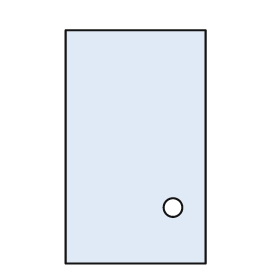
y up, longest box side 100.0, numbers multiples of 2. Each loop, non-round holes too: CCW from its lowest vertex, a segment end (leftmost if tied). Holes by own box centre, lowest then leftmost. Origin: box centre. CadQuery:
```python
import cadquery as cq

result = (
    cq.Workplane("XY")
    .moveTo(-30.0, -50.0)
    .lineTo(30.0, -50.0)
    .lineTo(30.0, 50.0)
    .lineTo(-30.0, 50.0)
    .close()
    .moveTo(16.0, -26.0)
    .circle(4.0)
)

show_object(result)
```